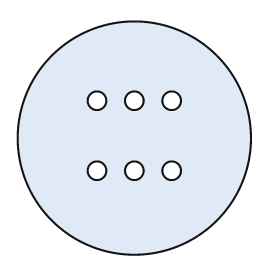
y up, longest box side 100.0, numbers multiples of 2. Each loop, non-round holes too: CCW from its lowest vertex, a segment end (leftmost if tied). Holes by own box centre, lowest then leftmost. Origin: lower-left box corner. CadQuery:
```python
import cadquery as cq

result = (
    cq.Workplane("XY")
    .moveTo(50.0, 50.0)
    .circle(50.0)
    .moveTo(34.0, 36.0)
    .circle(4.0)
    .moveTo(50.0, 36.0)
    .circle(4.0)
    .moveTo(66.0, 36.0)
    .circle(4.0)
    .moveTo(34.0, 66.0)
    .circle(4.0)
    .moveTo(50.0, 66.0)
    .circle(4.0)
    .moveTo(66.0, 66.0)
    .circle(4.0)
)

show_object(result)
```